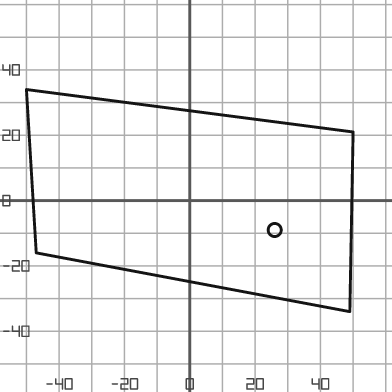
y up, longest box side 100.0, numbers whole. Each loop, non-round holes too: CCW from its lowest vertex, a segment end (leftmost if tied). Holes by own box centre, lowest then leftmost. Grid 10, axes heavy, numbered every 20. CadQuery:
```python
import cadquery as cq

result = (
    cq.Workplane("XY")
    .moveTo(49.0, -34.0)
    .lineTo(50.0, 21.0)
    .lineTo(-50.0, 34.0)
    .lineTo(-47.0, -16.0)
    .close()
    .moveTo(26.0, -9.0)
    .circle(2.0)
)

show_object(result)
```